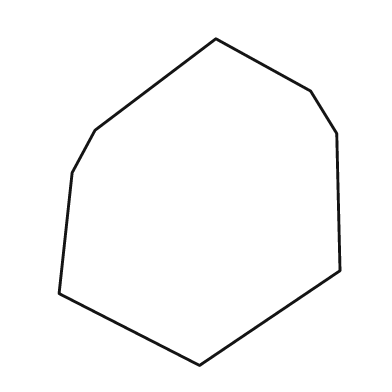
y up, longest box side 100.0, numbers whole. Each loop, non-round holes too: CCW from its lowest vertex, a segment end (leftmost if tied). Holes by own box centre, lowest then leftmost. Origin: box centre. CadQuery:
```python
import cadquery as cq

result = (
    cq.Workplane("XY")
    .moveTo(0.0, -50.0)
    .lineTo(43.0, -21.0)
    .lineTo(42.0, 21.0)
    .lineTo(34.0, 34.0)
    .lineTo(5.0, 50.0)
    .lineTo(-32.0, 22.0)
    .lineTo(-39.0, 9.0)
    .lineTo(-43.0, -28.0)
    .close()
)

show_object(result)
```